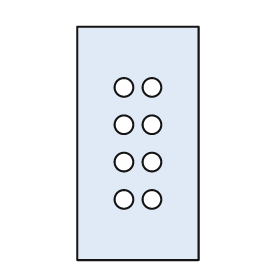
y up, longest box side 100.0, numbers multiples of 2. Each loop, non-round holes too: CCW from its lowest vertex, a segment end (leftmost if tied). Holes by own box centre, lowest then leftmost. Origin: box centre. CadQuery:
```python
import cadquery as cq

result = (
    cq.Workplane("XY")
    .moveTo(-26.0, -50.0)
    .lineTo(26.0, -50.0)
    .lineTo(26.0, 50.0)
    .lineTo(-26.0, 50.0)
    .close()
    .moveTo(-6.0, -24.0)
    .circle(4.0)
    .moveTo(6.0, -24.0)
    .circle(4.0)
    .moveTo(-6.0, -8.0)
    .circle(4.0)
    .moveTo(6.0, -8.0)
    .circle(4.0)
    .moveTo(-6.0, 8.0)
    .circle(4.0)
    .moveTo(6.0, 8.0)
    .circle(4.0)
    .moveTo(-6.0, 24.0)
    .circle(4.0)
    .moveTo(6.0, 24.0)
    .circle(4.0)
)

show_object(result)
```